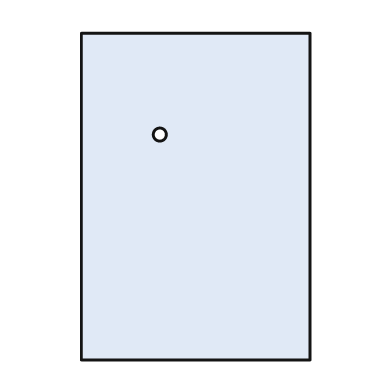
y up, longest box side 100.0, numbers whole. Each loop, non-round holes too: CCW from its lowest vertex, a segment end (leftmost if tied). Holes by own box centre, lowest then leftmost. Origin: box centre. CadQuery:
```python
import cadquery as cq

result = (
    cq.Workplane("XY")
    .moveTo(-35.0, -50.0)
    .lineTo(35.0, -50.0)
    .lineTo(35.0, 50.0)
    .lineTo(-35.0, 50.0)
    .close()
    .moveTo(-11.0, 19.0)
    .circle(2.0)
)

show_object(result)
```